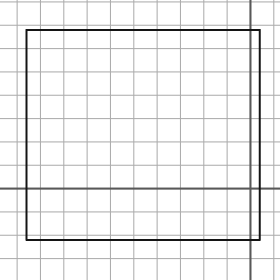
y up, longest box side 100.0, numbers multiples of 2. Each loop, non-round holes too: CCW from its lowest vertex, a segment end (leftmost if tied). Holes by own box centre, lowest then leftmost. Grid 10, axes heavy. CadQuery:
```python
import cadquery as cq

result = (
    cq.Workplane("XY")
    .moveTo(-96.0, -22.0)
    .lineTo(4.0, -22.0)
    .lineTo(4.0, 68.0)
    .lineTo(-96.0, 68.0)
    .close()
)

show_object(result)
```